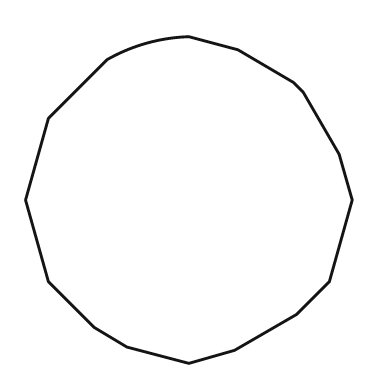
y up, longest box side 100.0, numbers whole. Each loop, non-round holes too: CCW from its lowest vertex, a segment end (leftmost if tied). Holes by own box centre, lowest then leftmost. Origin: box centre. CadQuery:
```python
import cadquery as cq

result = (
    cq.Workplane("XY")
    .moveTo(0.0, -50.0)
    .lineTo(14.0, -46.0)
    .lineTo(33.0, -35.0)
    .lineTo(43.0, -25.0)
    .lineTo(50.0, 0.0)
    .lineTo(46.0, 14.0)
    .lineTo(35.0, 33.0)
    .lineTo(32.0, 36.0)
    .lineTo(15.0, 46.0)
    .lineTo(0.0, 50.0)
    .threePointArc((-13.0, 48.0), (-25.0, 43.0))
    .lineTo(-43.0, 25.0)
    .lineTo(-50.0, 0.0)
    .lineTo(-43.0, -25.0)
    .lineTo(-29.0, -39.0)
    .lineTo(-19.0, -45.0)
    .close()
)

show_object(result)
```